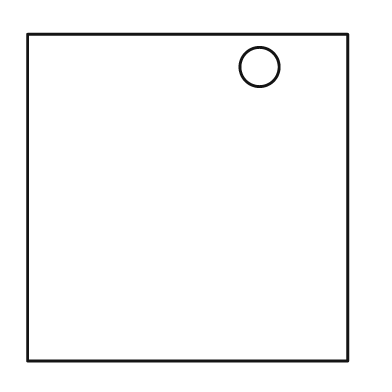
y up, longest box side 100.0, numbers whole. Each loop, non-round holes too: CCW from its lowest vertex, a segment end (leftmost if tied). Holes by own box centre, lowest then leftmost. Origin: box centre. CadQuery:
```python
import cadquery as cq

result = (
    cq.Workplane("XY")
    .moveTo(-49.0, -50.0)
    .lineTo(49.0, -50.0)
    .lineTo(49.0, 50.0)
    .lineTo(-49.0, 50.0)
    .close()
    .moveTo(22.0, 40.0)
    .circle(6.0)
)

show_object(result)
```